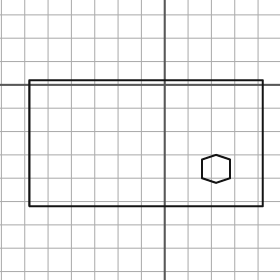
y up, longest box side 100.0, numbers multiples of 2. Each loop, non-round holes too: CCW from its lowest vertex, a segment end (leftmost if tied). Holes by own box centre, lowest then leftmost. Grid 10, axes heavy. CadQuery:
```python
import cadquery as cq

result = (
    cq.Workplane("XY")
    .moveTo(-58.0, -52.0)
    .lineTo(42.0, -52.0)
    .lineTo(42.0, 2.0)
    .lineTo(-58.0, 2.0)
    .close()
    .moveTo(22.0, -42.0)
    .lineTo(28.0, -40.0)
    .lineTo(28.0, -32.0)
    .lineTo(22.0, -30.0)
    .lineTo(16.0, -32.0)
    .lineTo(16.0, -40.0)
    .close()
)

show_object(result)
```